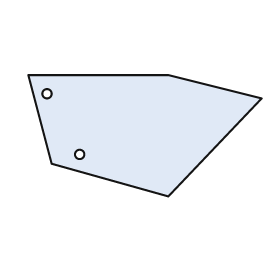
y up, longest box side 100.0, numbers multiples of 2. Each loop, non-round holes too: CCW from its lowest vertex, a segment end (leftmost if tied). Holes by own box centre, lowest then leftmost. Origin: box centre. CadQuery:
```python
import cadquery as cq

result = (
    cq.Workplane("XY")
    .moveTo(10.0, -26.0)
    .lineTo(50.0, 16.0)
    .lineTo(10.0, 26.0)
    .lineTo(-50.0, 26.0)
    .lineTo(-40.0, -12.0)
    .close()
    .moveTo(-28.0, -8.0)
    .circle(2.0)
    .moveTo(-42.0, 18.0)
    .circle(2.0)
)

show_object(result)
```